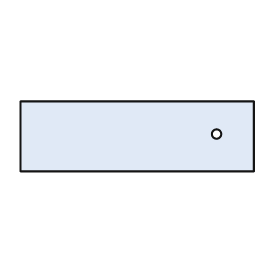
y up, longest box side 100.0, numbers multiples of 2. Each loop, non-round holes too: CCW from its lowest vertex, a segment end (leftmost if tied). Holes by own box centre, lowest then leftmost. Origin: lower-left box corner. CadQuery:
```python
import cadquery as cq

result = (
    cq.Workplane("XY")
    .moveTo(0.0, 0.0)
    .lineTo(100.0, 0.0)
    .lineTo(100.0, 30.0)
    .lineTo(0.0, 30.0)
    .close()
    .moveTo(84.0, 16.0)
    .circle(2.0)
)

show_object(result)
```